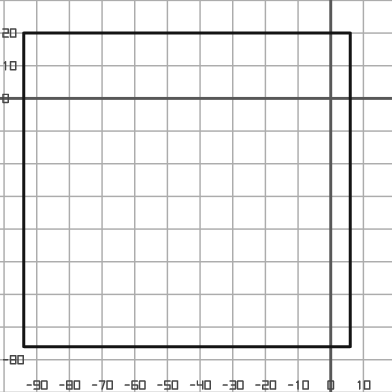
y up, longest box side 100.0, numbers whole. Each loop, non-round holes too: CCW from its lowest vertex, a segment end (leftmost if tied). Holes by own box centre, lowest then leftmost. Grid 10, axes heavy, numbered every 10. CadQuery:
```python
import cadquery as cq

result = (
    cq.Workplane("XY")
    .moveTo(-94.0, -76.0)
    .lineTo(6.0, -76.0)
    .lineTo(6.0, 20.0)
    .lineTo(-94.0, 20.0)
    .close()
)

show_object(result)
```